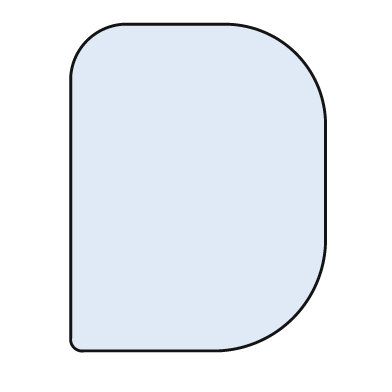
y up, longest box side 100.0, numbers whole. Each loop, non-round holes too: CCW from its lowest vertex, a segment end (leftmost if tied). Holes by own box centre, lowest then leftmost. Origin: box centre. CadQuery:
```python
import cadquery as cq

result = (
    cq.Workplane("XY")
    .moveTo(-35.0, -50.0)
    .lineTo(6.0, -50.0)
    .threePointArc((29.0, -40.0), (39.0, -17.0))
    .lineTo(39.0, 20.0)
    .threePointArc((30.0, 41.0), (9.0, 50.0))
    .lineTo(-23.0, 50.0)
    .threePointArc((-34.0, 45.0), (-39.0, 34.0))
    .lineTo(-39.0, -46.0)
    .threePointArc((-38.0, -49.0), (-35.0, -50.0))
    .close()
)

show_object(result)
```